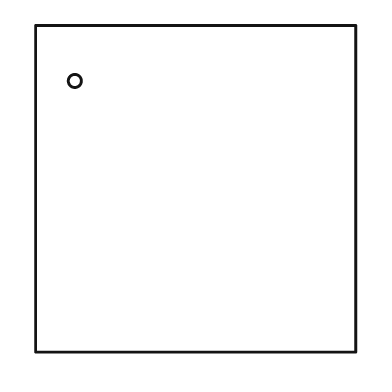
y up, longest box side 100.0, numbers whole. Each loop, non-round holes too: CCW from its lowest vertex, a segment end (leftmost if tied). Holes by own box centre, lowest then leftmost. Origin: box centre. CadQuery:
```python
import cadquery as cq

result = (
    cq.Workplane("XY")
    .moveTo(-49.0, -50.0)
    .lineTo(49.0, -50.0)
    .lineTo(49.0, 50.0)
    .lineTo(-49.0, 50.0)
    .close()
    .moveTo(-37.0, 33.0)
    .circle(2.0)
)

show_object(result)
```